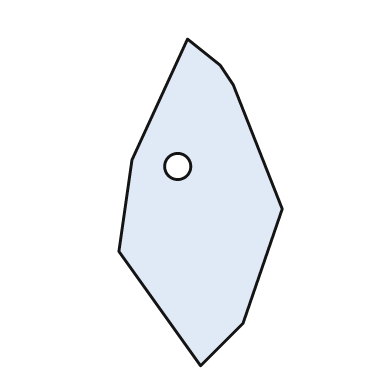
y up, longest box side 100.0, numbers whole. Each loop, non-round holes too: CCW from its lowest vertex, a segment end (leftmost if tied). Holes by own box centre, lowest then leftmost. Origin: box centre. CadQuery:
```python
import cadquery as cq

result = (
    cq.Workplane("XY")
    .moveTo(0.0, -50.0)
    .lineTo(13.0, -37.0)
    .lineTo(25.0, -2.0)
    .lineTo(10.0, 36.0)
    .lineTo(6.0, 42.0)
    .lineTo(-4.0, 50.0)
    .lineTo(-21.0, 13.0)
    .lineTo(-25.0, -15.0)
    .close()
    .moveTo(-7.0, 11.0)
    .circle(4.0)
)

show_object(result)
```